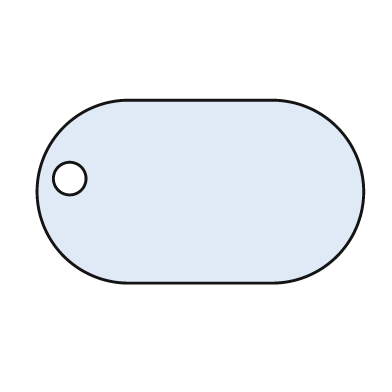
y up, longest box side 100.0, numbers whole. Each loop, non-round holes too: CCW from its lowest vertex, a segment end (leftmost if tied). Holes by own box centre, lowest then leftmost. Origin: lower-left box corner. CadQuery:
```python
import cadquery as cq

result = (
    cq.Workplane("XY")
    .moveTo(28.0, 0.0)
    .lineTo(72.0, 0.0)
    .threePointArc((100.0, 28.0), (72.0, 56.0))
    .lineTo(28.0, 56.0)
    .threePointArc((0.0, 28.0), (28.0, 0.0))
    .close()
    .moveTo(10.0, 32.0)
    .circle(5.0)
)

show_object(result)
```